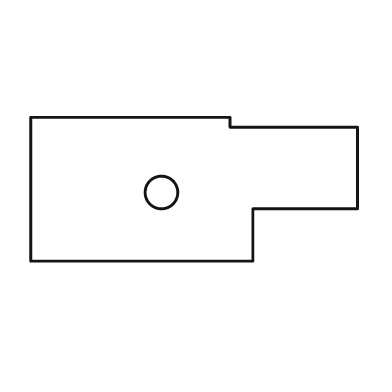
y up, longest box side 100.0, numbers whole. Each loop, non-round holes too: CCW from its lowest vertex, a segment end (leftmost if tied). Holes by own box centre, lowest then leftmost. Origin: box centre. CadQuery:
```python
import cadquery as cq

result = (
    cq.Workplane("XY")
    .moveTo(-50.0, -22.0)
    .lineTo(18.0, -22.0)
    .lineTo(18.0, -6.0)
    .lineTo(50.0, -6.0)
    .lineTo(50.0, 19.0)
    .lineTo(11.0, 19.0)
    .lineTo(11.0, 22.0)
    .lineTo(-50.0, 22.0)
    .close()
    .moveTo(-10.0, -1.0)
    .circle(5.0)
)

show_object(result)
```